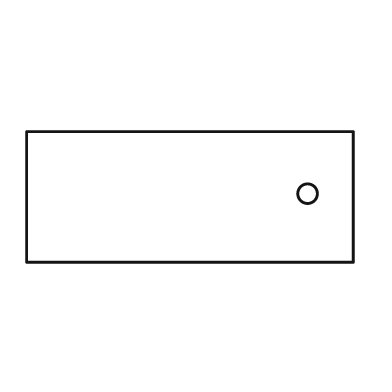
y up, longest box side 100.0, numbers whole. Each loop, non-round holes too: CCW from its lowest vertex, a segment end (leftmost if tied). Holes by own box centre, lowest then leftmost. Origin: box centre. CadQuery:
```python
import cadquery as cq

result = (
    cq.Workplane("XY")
    .moveTo(-50.0, -20.0)
    .lineTo(50.0, -20.0)
    .lineTo(50.0, 20.0)
    .lineTo(-50.0, 20.0)
    .close()
    .moveTo(36.0, 1.0)
    .circle(3.0)
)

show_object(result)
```